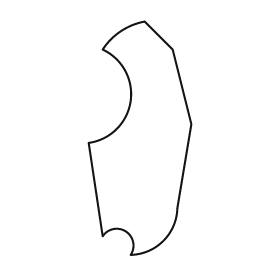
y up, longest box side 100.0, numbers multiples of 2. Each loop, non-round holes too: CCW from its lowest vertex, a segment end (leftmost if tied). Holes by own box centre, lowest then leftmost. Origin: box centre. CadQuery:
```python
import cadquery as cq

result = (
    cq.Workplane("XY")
    .moveTo(-4.0, -50.0)
    .threePointArc((10.0, -44.0), (16.0, -30.0))
    .lineTo(22.0, 6.0)
    .lineTo(14.0, 38.0)
    .lineTo(2.0, 50.0)
    .threePointArc((-8.0, 46.0), (-16.0, 38.0))
    .threePointArc((-4.0, 16.0), (-22.0, -2.0))
    .lineTo(-16.0, -42.0)
    .threePointArc((-6.0, -40.0), (-4.0, -50.0))
    .close()
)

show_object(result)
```